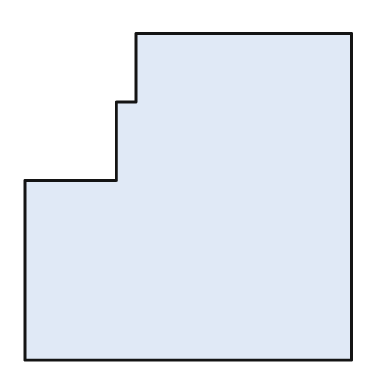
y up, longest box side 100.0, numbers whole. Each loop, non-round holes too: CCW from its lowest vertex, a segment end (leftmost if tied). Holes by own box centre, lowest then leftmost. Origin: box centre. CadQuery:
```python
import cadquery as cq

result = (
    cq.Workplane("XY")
    .moveTo(-50.0, -50.0)
    .lineTo(50.0, -50.0)
    .lineTo(50.0, 50.0)
    .lineTo(-16.0, 50.0)
    .lineTo(-16.0, 29.0)
    .lineTo(-22.0, 29.0)
    .lineTo(-22.0, 5.0)
    .lineTo(-50.0, 5.0)
    .close()
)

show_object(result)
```